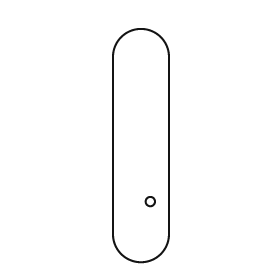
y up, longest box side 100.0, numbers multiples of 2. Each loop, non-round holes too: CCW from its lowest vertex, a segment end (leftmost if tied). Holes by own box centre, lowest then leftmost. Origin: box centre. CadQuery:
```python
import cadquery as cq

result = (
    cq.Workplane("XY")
    .moveTo(-12.0, -38.0)
    .threePointArc((0.0, -50.0), (12.0, -38.0))
    .lineTo(12.0, 38.0)
    .threePointArc((0.0, 50.0), (-12.0, 38.0))
    .close()
    .moveTo(4.0, -24.0)
    .circle(2.0)
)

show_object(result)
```